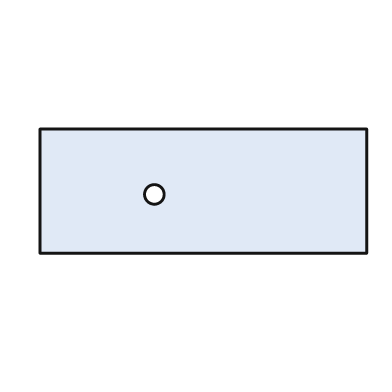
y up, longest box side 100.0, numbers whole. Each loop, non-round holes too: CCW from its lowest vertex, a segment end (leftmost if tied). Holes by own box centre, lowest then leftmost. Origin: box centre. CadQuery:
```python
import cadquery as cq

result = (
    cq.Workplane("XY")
    .moveTo(-50.0, -19.0)
    .lineTo(50.0, -19.0)
    .lineTo(50.0, 19.0)
    .lineTo(-50.0, 19.0)
    .close()
    .moveTo(-15.0, -1.0)
    .circle(3.0)
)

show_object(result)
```